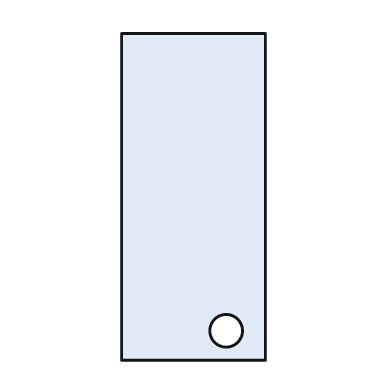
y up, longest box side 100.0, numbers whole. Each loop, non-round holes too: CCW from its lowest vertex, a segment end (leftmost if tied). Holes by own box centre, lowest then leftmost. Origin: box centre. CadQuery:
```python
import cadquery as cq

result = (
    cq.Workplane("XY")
    .moveTo(-22.0, -50.0)
    .lineTo(22.0, -50.0)
    .lineTo(22.0, 50.0)
    .lineTo(-22.0, 50.0)
    .close()
    .moveTo(10.0, -41.0)
    .circle(5.0)
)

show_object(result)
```